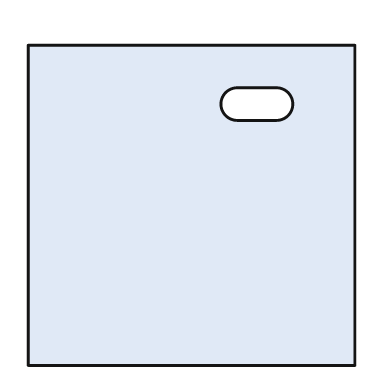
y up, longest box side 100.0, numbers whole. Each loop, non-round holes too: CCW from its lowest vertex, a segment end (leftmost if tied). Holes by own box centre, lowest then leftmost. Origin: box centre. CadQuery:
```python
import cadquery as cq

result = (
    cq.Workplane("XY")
    .moveTo(-50.0, -49.0)
    .lineTo(50.0, -49.0)
    .lineTo(50.0, 49.0)
    .lineTo(-50.0, 49.0)
    .close()
    .moveTo(14.0, 26.0)
    .lineTo(26.0, 26.0)
    .threePointArc((31.0, 31.0), (26.0, 36.0))
    .lineTo(14.0, 36.0)
    .threePointArc((9.0, 31.0), (14.0, 26.0))
    .close()
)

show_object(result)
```